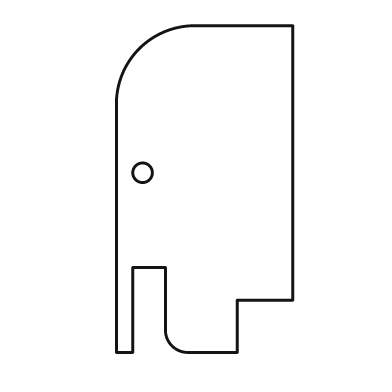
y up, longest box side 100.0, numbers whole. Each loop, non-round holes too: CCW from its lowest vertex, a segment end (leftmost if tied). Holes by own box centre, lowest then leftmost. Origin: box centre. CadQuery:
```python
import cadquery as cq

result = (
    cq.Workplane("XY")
    .moveTo(-27.0, -50.0)
    .lineTo(-22.0, -50.0)
    .lineTo(-22.0, -24.0)
    .lineTo(-12.0, -24.0)
    .lineTo(-12.0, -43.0)
    .threePointArc((-10.0, -48.0), (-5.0, -50.0))
    .lineTo(10.0, -50.0)
    .lineTo(10.0, -34.0)
    .lineTo(27.0, -34.0)
    .lineTo(27.0, 50.0)
    .lineTo(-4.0, 50.0)
    .threePointArc((-20.0, 43.0), (-27.0, 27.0))
    .close()
    .moveTo(-19.0, 5.0)
    .circle(3.0)
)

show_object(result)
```